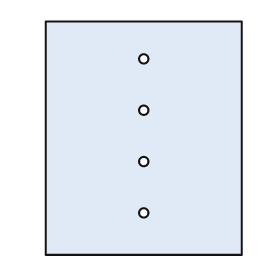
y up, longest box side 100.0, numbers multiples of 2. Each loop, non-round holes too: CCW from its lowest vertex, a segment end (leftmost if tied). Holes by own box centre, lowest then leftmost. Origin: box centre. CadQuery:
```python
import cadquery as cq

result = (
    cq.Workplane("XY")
    .moveTo(-42.0, -50.0)
    .lineTo(42.0, -50.0)
    .lineTo(42.0, 50.0)
    .lineTo(-42.0, 50.0)
    .close()
    .moveTo(0.0, -32.0)
    .circle(2.0)
    .moveTo(0.0, -10.0)
    .circle(2.0)
    .moveTo(0.0, 12.0)
    .circle(2.0)
    .moveTo(0.0, 34.0)
    .circle(2.0)
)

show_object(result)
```